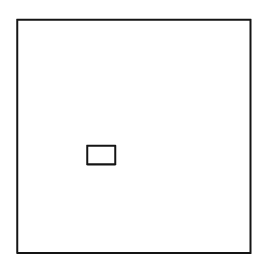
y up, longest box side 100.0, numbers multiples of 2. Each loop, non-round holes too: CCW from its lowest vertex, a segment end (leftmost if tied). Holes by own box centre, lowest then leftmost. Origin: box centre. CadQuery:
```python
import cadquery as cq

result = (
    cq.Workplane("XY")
    .moveTo(-50.0, -50.0)
    .lineTo(50.0, -50.0)
    .lineTo(50.0, 50.0)
    .lineTo(-50.0, 50.0)
    .close()
    .moveTo(-20.0, -12.0)
    .lineTo(-8.0, -12.0)
    .lineTo(-8.0, -4.0)
    .lineTo(-20.0, -4.0)
    .close()
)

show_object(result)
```